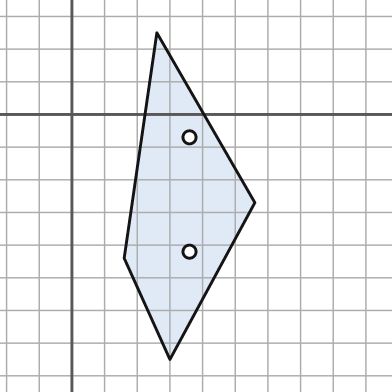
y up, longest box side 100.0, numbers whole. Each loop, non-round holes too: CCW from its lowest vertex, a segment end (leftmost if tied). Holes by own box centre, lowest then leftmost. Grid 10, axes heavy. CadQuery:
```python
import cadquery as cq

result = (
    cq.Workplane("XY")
    .moveTo(30.0, -75.0)
    .lineTo(56.0, -27.0)
    .lineTo(26.0, 25.0)
    .lineTo(16.0, -44.0)
    .close()
    .moveTo(36.0, -42.0)
    .circle(2.0)
    .moveTo(36.0, -7.0)
    .circle(2.0)
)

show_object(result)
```